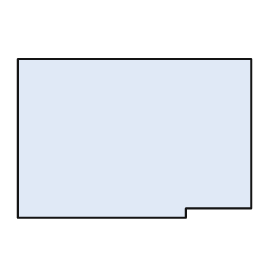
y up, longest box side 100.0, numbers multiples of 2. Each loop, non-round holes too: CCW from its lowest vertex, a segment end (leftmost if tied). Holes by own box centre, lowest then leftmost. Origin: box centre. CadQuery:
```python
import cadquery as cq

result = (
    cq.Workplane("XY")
    .moveTo(-50.0, -34.0)
    .lineTo(22.0, -34.0)
    .lineTo(22.0, -30.0)
    .lineTo(50.0, -30.0)
    .lineTo(50.0, 34.0)
    .lineTo(-50.0, 34.0)
    .close()
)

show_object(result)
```